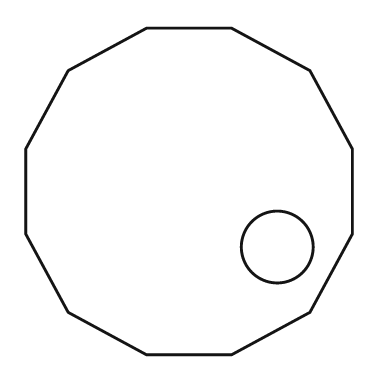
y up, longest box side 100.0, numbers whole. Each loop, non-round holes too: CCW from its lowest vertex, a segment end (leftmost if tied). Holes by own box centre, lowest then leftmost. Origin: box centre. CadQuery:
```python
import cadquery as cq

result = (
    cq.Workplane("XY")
    .moveTo(-13.0, -50.0)
    .lineTo(13.0, -50.0)
    .lineTo(37.0, -37.0)
    .lineTo(50.0, -13.0)
    .lineTo(50.0, 13.0)
    .lineTo(37.0, 37.0)
    .lineTo(13.0, 50.0)
    .lineTo(-13.0, 50.0)
    .lineTo(-37.0, 37.0)
    .lineTo(-50.0, 13.0)
    .lineTo(-50.0, -13.0)
    .lineTo(-37.0, -37.0)
    .close()
    .moveTo(27.0, -17.0)
    .circle(11.0)
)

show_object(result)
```